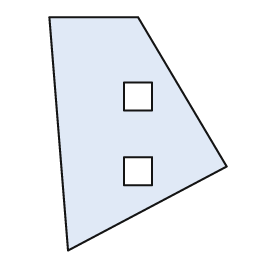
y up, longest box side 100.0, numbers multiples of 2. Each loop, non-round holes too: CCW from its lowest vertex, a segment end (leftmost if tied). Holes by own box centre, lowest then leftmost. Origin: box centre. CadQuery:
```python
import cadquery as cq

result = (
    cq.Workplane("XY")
    .moveTo(-30.0, -50.0)
    .lineTo(38.0, -14.0)
    .lineTo(0.0, 50.0)
    .lineTo(-38.0, 50.0)
    .close()
    .moveTo(-6.0, -22.0)
    .lineTo(6.0, -22.0)
    .lineTo(6.0, -10.0)
    .lineTo(-6.0, -10.0)
    .close()
    .moveTo(-6.0, 10.0)
    .lineTo(6.0, 10.0)
    .lineTo(6.0, 22.0)
    .lineTo(-6.0, 22.0)
    .close()
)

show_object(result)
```